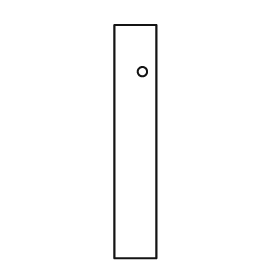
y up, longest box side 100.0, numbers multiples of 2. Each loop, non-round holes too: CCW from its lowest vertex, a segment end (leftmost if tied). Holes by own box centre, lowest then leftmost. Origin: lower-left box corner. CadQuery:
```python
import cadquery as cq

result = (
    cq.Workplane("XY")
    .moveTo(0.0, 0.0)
    .lineTo(18.0, 0.0)
    .lineTo(18.0, 100.0)
    .lineTo(0.0, 100.0)
    .close()
    .moveTo(12.0, 80.0)
    .circle(2.0)
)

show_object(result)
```